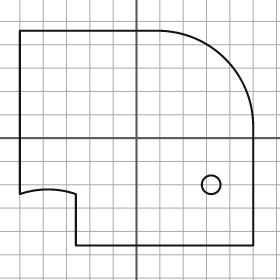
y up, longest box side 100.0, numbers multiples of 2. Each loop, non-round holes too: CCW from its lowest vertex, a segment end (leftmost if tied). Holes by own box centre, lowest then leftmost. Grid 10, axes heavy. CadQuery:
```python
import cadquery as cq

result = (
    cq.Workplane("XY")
    .moveTo(-26.0, -46.0)
    .lineTo(50.0, -46.0)
    .lineTo(50.0, 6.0)
    .threePointArc((38.0, 34.0), (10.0, 46.0))
    .lineTo(-50.0, 46.0)
    .lineTo(-50.0, -24.0)
    .threePointArc((-38.0, -22.0), (-26.0, -24.0))
    .close()
    .moveTo(32.0, -20.0)
    .circle(4.0)
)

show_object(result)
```